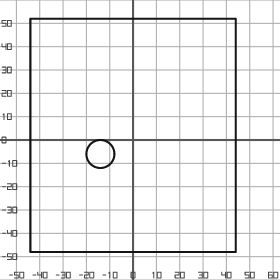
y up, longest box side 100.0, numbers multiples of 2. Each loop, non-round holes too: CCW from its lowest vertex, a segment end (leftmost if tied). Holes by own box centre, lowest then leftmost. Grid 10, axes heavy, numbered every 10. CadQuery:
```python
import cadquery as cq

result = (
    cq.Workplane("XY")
    .moveTo(-44.0, -48.0)
    .lineTo(44.0, -48.0)
    .lineTo(44.0, 52.0)
    .lineTo(-44.0, 52.0)
    .close()
    .moveTo(-14.0, -6.0)
    .circle(6.0)
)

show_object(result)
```